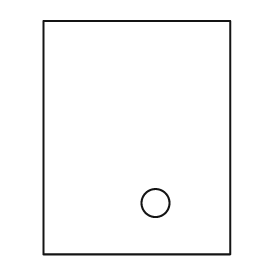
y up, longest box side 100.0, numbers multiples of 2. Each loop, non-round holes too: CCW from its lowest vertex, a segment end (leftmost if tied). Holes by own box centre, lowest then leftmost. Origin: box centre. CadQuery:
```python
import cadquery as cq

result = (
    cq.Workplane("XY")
    .moveTo(-40.0, -50.0)
    .lineTo(40.0, -50.0)
    .lineTo(40.0, 50.0)
    .lineTo(-40.0, 50.0)
    .close()
    .moveTo(8.0, -28.0)
    .circle(6.0)
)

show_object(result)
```